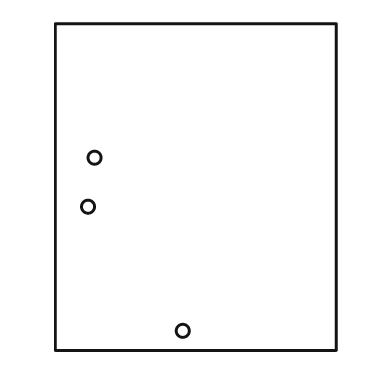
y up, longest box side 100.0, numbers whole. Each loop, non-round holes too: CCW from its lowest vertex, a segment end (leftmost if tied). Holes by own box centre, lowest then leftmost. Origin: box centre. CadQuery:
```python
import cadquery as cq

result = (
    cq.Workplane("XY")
    .moveTo(-43.0, -50.0)
    .lineTo(43.0, -50.0)
    .lineTo(43.0, 50.0)
    .lineTo(-43.0, 50.0)
    .close()
    .moveTo(-4.0, -44.0)
    .circle(2.0)
    .moveTo(-33.0, -6.0)
    .circle(2.0)
    .moveTo(-31.0, 9.0)
    .circle(2.0)
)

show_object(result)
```